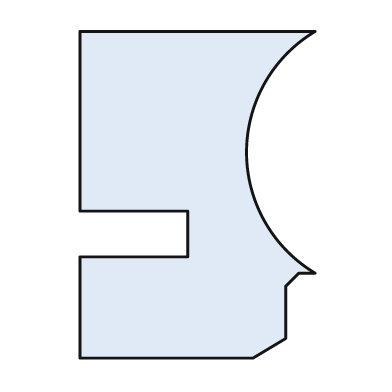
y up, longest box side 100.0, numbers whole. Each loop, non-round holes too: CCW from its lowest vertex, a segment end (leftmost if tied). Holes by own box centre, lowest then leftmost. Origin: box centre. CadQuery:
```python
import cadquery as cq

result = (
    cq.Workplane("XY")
    .moveTo(-36.0, -50.0)
    .lineTo(17.0, -50.0)
    .lineTo(27.0, -44.0)
    .lineTo(27.0, -28.0)
    .lineTo(31.0, -24.0)
    .lineTo(36.0, -24.0)
    .threePointArc((15.0, 13.0), (36.0, 50.0))
    .lineTo(-36.0, 50.0)
    .lineTo(-36.0, -5.0)
    .lineTo(-3.0, -5.0)
    .lineTo(-3.0, -19.0)
    .lineTo(-36.0, -19.0)
    .close()
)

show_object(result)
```